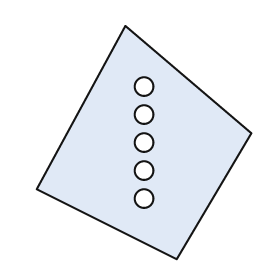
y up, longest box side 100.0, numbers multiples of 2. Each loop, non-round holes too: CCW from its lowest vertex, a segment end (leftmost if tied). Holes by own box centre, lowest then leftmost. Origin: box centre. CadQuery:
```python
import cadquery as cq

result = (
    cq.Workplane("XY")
    .moveTo(14.0, -50.0)
    .lineTo(46.0, 4.0)
    .lineTo(-8.0, 50.0)
    .lineTo(-46.0, -20.0)
    .close()
    .moveTo(0.0, -24.0)
    .circle(4.0)
    .moveTo(0.0, -12.0)
    .circle(4.0)
    .moveTo(0.0, 0.0)
    .circle(4.0)
    .moveTo(0.0, 12.0)
    .circle(4.0)
    .moveTo(0.0, 24.0)
    .circle(4.0)
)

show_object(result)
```